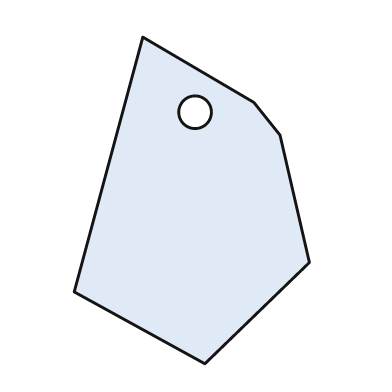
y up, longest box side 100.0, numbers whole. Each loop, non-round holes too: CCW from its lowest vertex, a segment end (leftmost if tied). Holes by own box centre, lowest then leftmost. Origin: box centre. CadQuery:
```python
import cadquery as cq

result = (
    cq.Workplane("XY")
    .moveTo(4.0, -50.0)
    .lineTo(36.0, -19.0)
    .lineTo(27.0, 20.0)
    .lineTo(19.0, 30.0)
    .lineTo(-15.0, 50.0)
    .lineTo(-36.0, -28.0)
    .close()
    .moveTo(1.0, 27.0)
    .circle(5.0)
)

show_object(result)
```